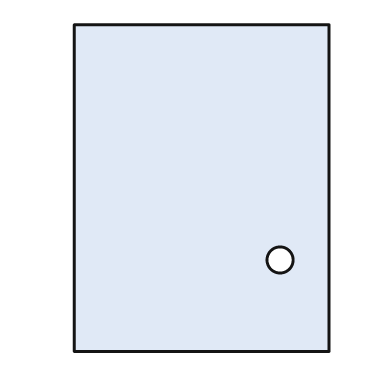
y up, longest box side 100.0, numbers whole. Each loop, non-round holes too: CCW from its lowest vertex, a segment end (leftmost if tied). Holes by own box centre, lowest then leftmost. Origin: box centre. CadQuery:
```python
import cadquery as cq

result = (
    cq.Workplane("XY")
    .moveTo(-39.0, -50.0)
    .lineTo(39.0, -50.0)
    .lineTo(39.0, 50.0)
    .lineTo(-39.0, 50.0)
    .close()
    .moveTo(24.0, -22.0)
    .circle(4.0)
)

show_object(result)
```